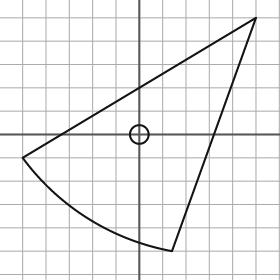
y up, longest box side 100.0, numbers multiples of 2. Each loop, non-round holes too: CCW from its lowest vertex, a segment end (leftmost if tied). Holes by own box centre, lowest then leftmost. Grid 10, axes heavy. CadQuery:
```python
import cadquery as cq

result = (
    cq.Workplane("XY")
    .moveTo(14.0, -50.0)
    .lineTo(50.0, 50.0)
    .lineTo(-50.0, -10.0)
    .threePointArc((-22.0, -36.0), (14.0, -50.0))
    .close()
    .moveTo(0.0, 0.0)
    .circle(4.0)
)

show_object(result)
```